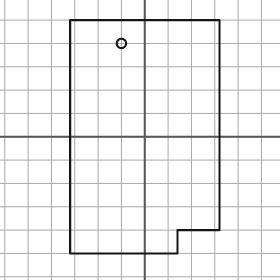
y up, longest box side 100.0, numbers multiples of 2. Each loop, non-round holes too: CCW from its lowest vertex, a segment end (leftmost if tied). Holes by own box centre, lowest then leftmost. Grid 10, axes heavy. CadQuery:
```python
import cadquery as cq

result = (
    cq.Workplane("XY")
    .moveTo(-32.0, -50.0)
    .lineTo(14.0, -50.0)
    .lineTo(14.0, -40.0)
    .lineTo(32.0, -40.0)
    .lineTo(32.0, 50.0)
    .lineTo(-32.0, 50.0)
    .close()
    .moveTo(-10.0, 40.0)
    .circle(2.0)
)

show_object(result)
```